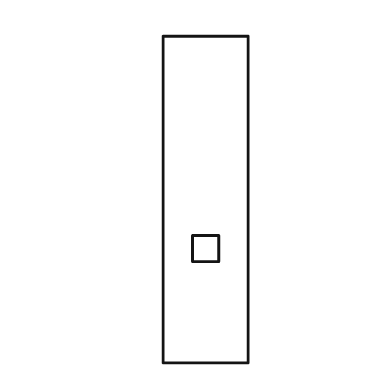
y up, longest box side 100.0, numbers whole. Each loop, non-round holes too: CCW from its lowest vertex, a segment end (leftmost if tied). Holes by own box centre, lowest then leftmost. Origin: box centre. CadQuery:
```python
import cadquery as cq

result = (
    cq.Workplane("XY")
    .moveTo(-13.0, -50.0)
    .lineTo(13.0, -50.0)
    .lineTo(13.0, 50.0)
    .lineTo(-13.0, 50.0)
    .close()
    .moveTo(-4.0, -19.0)
    .lineTo(4.0, -19.0)
    .lineTo(4.0, -11.0)
    .lineTo(-4.0, -11.0)
    .close()
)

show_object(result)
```